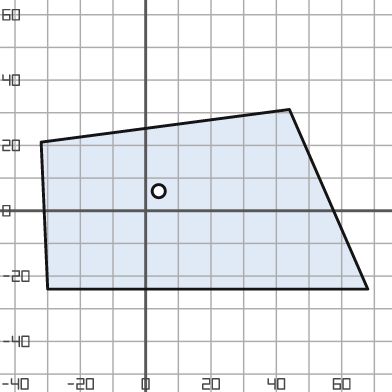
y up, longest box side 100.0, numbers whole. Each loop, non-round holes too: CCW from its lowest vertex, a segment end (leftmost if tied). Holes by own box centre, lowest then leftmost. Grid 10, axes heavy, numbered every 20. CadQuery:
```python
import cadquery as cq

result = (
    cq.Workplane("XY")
    .moveTo(-30.0, -24.0)
    .lineTo(68.0, -24.0)
    .lineTo(44.0, 31.0)
    .lineTo(-32.0, 21.0)
    .close()
    .moveTo(4.0, 6.0)
    .circle(2.0)
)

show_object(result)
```